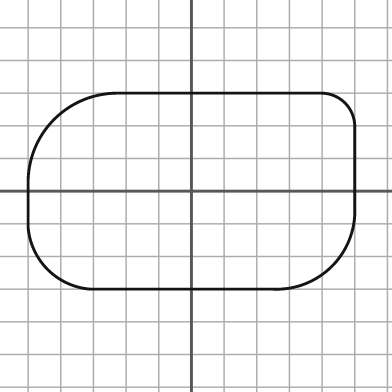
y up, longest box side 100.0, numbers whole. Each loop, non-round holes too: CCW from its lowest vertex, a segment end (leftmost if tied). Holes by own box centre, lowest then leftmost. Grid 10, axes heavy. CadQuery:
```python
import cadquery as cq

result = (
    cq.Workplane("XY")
    .moveTo(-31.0, -30.0)
    .lineTo(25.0, -30.0)
    .threePointArc((43.0, -23.0), (50.0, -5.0))
    .lineTo(50.0, 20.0)
    .threePointArc((47.0, 27.0), (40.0, 30.0))
    .lineTo(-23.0, 30.0)
    .threePointArc((-42.0, 22.0), (-50.0, 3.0))
    .lineTo(-50.0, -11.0)
    .threePointArc((-44.0, -24.0), (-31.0, -30.0))
    .close()
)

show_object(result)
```